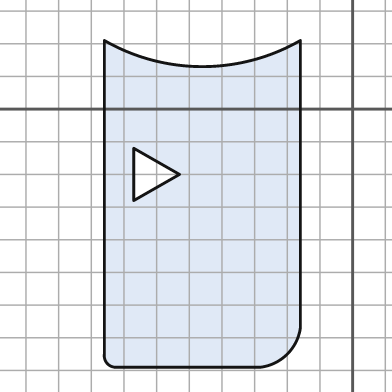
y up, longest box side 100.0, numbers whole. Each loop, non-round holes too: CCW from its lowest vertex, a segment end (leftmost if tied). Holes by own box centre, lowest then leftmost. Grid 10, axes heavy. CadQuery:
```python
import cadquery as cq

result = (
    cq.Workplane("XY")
    .moveTo(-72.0, -79.0)
    .lineTo(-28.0, -79.0)
    .threePointArc((-20.0, -75.0), (-16.0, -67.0))
    .lineTo(-16.0, 21.0)
    .threePointArc((-46.0, 13.0), (-76.0, 21.0))
    .lineTo(-76.0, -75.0)
    .threePointArc((-75.0, -78.0), (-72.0, -79.0))
    .close()
    .moveTo(-67.0, -28.0)
    .lineTo(-53.0, -20.0)
    .lineTo(-67.0, -12.0)
    .close()
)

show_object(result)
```